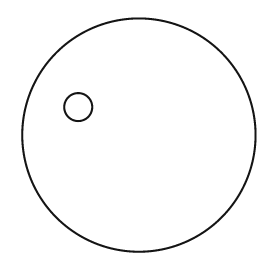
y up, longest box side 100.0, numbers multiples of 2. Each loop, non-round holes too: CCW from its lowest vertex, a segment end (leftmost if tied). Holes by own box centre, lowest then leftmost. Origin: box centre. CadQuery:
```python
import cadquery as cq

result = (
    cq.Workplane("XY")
    .moveTo(0.0, 0.0)
    .circle(50.0)
    .moveTo(-26.0, 12.0)
    .circle(6.0)
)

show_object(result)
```